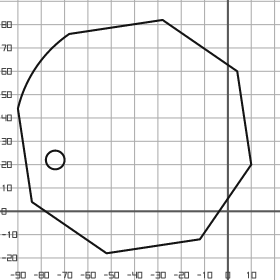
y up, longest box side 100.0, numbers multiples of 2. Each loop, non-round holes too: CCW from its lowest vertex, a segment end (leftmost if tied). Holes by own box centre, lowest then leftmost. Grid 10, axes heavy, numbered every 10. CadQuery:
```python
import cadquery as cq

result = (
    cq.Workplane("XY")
    .moveTo(-52.0, -18.0)
    .lineTo(-12.0, -12.0)
    .lineTo(10.0, 20.0)
    .lineTo(4.0, 60.0)
    .lineTo(-28.0, 82.0)
    .lineTo(-68.0, 76.0)
    .threePointArc((-82.0, 62.0), (-90.0, 44.0))
    .lineTo(-84.0, 4.0)
    .close()
    .moveTo(-74.0, 22.0)
    .circle(4.0)
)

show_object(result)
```